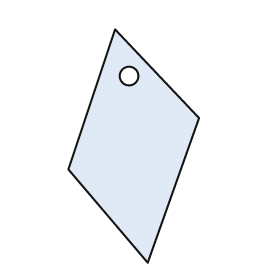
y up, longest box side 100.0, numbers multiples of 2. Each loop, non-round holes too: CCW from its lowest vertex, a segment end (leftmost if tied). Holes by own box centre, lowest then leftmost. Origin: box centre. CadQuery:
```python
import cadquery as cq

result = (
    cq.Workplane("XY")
    .moveTo(6.0, -50.0)
    .lineTo(28.0, 12.0)
    .lineTo(-8.0, 50.0)
    .lineTo(-28.0, -10.0)
    .close()
    .moveTo(-2.0, 30.0)
    .circle(4.0)
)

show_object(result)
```